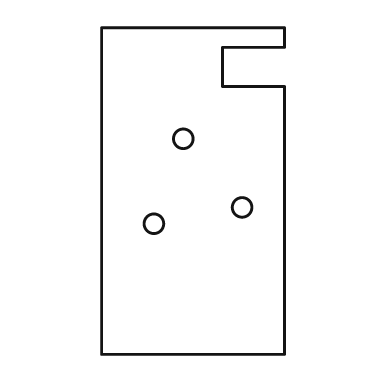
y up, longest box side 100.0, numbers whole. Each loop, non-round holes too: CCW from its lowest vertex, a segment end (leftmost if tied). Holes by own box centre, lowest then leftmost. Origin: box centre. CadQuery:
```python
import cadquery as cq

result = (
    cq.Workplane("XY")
    .moveTo(-28.0, -50.0)
    .lineTo(28.0, -50.0)
    .lineTo(28.0, 32.0)
    .lineTo(9.0, 32.0)
    .lineTo(9.0, 44.0)
    .lineTo(28.0, 44.0)
    .lineTo(28.0, 50.0)
    .lineTo(-28.0, 50.0)
    .close()
    .moveTo(-12.0, -10.0)
    .circle(3.0)
    .moveTo(15.0, -5.0)
    .circle(3.0)
    .moveTo(-3.0, 16.0)
    .circle(3.0)
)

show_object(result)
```